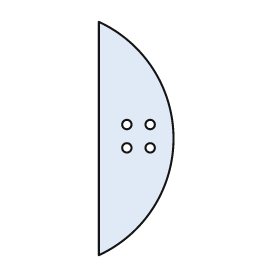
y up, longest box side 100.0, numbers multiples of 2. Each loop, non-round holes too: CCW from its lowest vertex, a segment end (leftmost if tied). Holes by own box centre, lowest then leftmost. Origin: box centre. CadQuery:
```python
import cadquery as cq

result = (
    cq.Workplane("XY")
    .moveTo(-16.0, -50.0)
    .threePointArc((16.0, 0.0), (-16.0, 50.0))
    .close()
    .moveTo(-4.0, -4.0)
    .circle(2.0)
    .moveTo(6.0, -4.0)
    .circle(2.0)
    .moveTo(-4.0, 6.0)
    .circle(2.0)
    .moveTo(6.0, 6.0)
    .circle(2.0)
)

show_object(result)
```